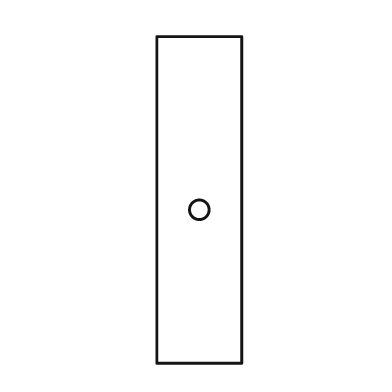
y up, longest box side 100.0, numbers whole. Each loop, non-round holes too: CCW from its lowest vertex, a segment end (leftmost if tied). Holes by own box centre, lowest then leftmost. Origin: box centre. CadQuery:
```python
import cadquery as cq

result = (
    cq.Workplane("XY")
    .moveTo(-13.0, -50.0)
    .lineTo(13.0, -50.0)
    .lineTo(13.0, 50.0)
    .lineTo(-13.0, 50.0)
    .close()
    .moveTo(0.0, -3.0)
    .circle(3.0)
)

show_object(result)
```